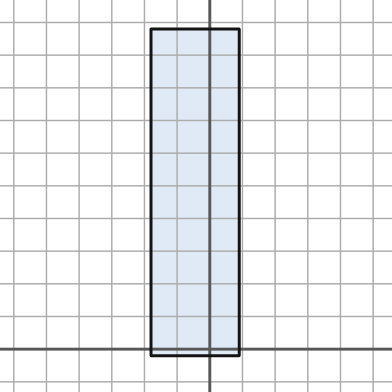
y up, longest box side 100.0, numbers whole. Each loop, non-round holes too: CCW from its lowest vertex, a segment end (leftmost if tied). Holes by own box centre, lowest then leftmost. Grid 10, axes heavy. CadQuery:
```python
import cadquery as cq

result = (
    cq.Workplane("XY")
    .moveTo(-18.0, -2.0)
    .lineTo(9.0, -2.0)
    .lineTo(9.0, 98.0)
    .lineTo(-18.0, 98.0)
    .close()
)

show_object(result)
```